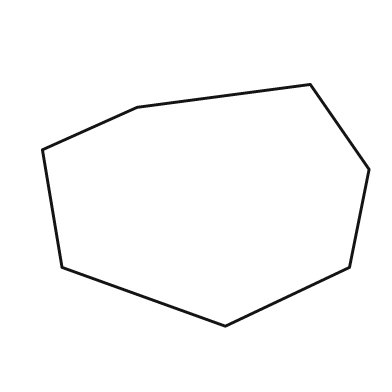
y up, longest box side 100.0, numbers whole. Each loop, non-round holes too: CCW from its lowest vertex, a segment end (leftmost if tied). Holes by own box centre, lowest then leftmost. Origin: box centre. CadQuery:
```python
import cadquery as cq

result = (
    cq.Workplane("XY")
    .moveTo(6.0, -37.0)
    .lineTo(44.0, -19.0)
    .lineTo(50.0, 11.0)
    .lineTo(32.0, 37.0)
    .lineTo(-21.0, 30.0)
    .lineTo(-50.0, 17.0)
    .lineTo(-44.0, -19.0)
    .close()
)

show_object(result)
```